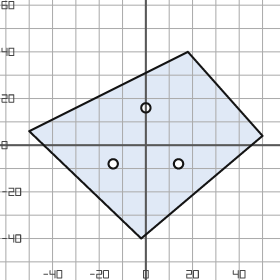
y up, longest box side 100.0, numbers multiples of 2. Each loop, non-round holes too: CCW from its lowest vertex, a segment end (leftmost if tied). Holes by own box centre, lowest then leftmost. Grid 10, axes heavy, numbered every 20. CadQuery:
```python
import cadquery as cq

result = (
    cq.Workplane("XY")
    .moveTo(-2.0, -40.0)
    .lineTo(50.0, 4.0)
    .lineTo(18.0, 40.0)
    .lineTo(-50.0, 6.0)
    .close()
    .moveTo(-14.0, -8.0)
    .circle(2.0)
    .moveTo(14.0, -8.0)
    .circle(2.0)
    .moveTo(0.0, 16.0)
    .circle(2.0)
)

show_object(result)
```